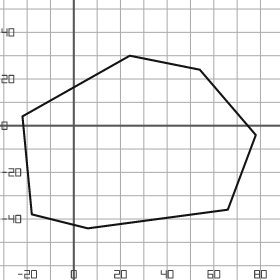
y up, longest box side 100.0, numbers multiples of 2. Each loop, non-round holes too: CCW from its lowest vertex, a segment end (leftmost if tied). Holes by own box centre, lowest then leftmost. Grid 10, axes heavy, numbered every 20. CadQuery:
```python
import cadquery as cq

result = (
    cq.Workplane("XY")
    .moveTo(6.0, -44.0)
    .lineTo(66.0, -36.0)
    .lineTo(78.0, -4.0)
    .lineTo(54.0, 24.0)
    .lineTo(24.0, 30.0)
    .lineTo(-22.0, 4.0)
    .lineTo(-18.0, -38.0)
    .close()
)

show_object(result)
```